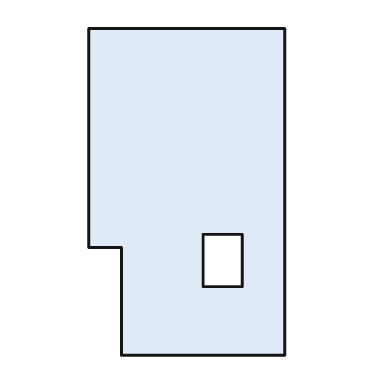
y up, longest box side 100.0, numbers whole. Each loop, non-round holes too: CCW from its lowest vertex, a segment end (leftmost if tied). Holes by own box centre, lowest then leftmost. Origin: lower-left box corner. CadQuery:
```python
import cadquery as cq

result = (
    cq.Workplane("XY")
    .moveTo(10.0, 0.0)
    .lineTo(60.0, 0.0)
    .lineTo(60.0, 100.0)
    .lineTo(0.0, 100.0)
    .lineTo(0.0, 33.0)
    .lineTo(10.0, 33.0)
    .close()
    .moveTo(35.0, 21.0)
    .lineTo(47.0, 21.0)
    .lineTo(47.0, 37.0)
    .lineTo(35.0, 37.0)
    .close()
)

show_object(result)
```